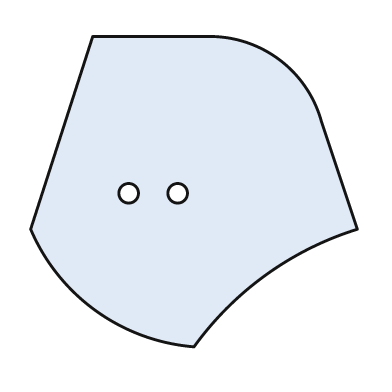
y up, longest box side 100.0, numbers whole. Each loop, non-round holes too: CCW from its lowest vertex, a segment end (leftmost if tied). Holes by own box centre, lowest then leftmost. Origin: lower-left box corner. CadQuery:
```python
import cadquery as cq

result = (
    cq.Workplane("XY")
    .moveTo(50.0, 0.0)
    .threePointArc((72.0, 22.0), (100.0, 36.0))
    .lineTo(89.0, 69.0)
    .threePointArc((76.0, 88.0), (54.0, 95.0))
    .lineTo(19.0, 95.0)
    .lineTo(0.0, 36.0)
    .threePointArc((20.0, 11.0), (50.0, 0.0))
    .close()
    .moveTo(30.0, 47.0)
    .circle(3.0)
    .moveTo(45.0, 47.0)
    .circle(3.0)
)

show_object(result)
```